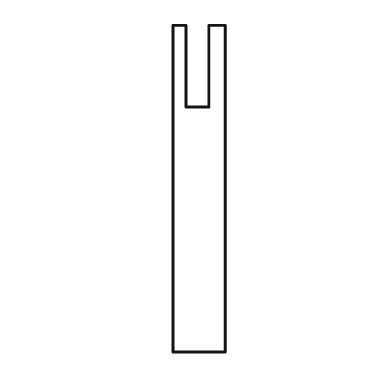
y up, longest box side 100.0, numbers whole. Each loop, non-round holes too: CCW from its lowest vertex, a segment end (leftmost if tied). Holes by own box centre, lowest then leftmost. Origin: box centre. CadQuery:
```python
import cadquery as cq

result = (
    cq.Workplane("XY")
    .moveTo(-8.0, -50.0)
    .lineTo(8.0, -50.0)
    .lineTo(8.0, 50.0)
    .lineTo(3.0, 50.0)
    .lineTo(3.0, 25.0)
    .lineTo(-4.0, 25.0)
    .lineTo(-4.0, 50.0)
    .lineTo(-8.0, 50.0)
    .close()
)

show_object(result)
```